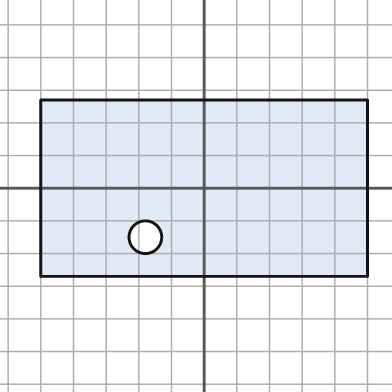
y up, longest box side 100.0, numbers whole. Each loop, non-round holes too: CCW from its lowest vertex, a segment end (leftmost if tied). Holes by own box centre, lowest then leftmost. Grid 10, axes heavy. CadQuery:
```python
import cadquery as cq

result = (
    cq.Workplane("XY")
    .moveTo(-50.0, -27.0)
    .lineTo(50.0, -27.0)
    .lineTo(50.0, 27.0)
    .lineTo(-50.0, 27.0)
    .close()
    .moveTo(-18.0, -15.0)
    .circle(5.0)
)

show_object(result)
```